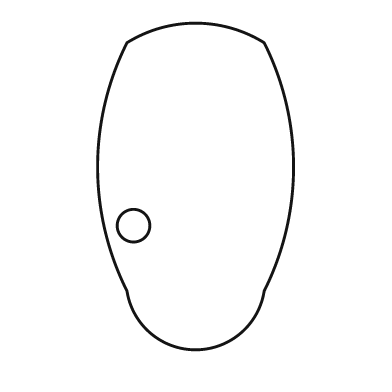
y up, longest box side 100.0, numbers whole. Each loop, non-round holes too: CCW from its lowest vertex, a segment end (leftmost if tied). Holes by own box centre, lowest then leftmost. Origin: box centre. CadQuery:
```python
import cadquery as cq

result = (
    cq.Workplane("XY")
    .moveTo(-21.0, -32.0)
    .threePointArc((0.0, -50.0), (21.0, -32.0))
    .threePointArc((30.0, 6.0), (21.0, 44.0))
    .threePointArc((0.0, 50.0), (-21.0, 44.0))
    .threePointArc((-30.0, 6.0), (-21.0, -32.0))
    .close()
    .moveTo(-19.0, -12.0)
    .circle(5.0)
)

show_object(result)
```